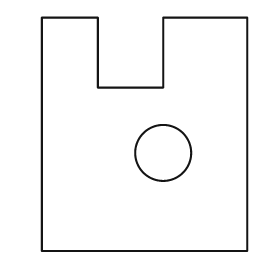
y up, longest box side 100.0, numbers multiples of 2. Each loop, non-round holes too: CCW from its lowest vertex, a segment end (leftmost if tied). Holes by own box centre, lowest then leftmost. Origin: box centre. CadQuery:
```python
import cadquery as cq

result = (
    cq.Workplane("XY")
    .moveTo(-44.0, -50.0)
    .lineTo(44.0, -50.0)
    .lineTo(44.0, 50.0)
    .lineTo(8.0, 50.0)
    .lineTo(8.0, 20.0)
    .lineTo(-20.0, 20.0)
    .lineTo(-20.0, 50.0)
    .lineTo(-44.0, 50.0)
    .close()
    .moveTo(8.0, -8.0)
    .circle(12.0)
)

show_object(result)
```